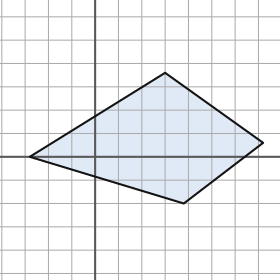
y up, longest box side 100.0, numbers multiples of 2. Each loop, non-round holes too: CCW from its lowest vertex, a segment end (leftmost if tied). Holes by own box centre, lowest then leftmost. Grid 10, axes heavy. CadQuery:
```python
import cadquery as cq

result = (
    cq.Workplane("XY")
    .moveTo(38.0, -20.0)
    .lineTo(72.0, 6.0)
    .lineTo(30.0, 36.0)
    .lineTo(-28.0, 0.0)
    .close()
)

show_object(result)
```